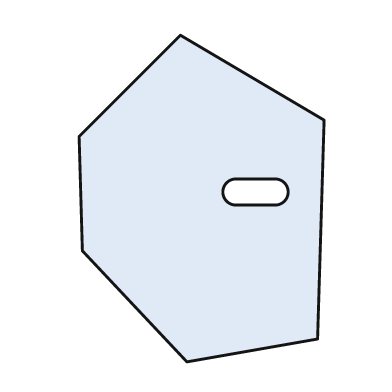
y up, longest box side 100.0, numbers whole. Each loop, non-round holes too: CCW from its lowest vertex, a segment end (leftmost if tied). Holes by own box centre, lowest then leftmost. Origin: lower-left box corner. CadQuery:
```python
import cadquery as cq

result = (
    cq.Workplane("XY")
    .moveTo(33.0, 0.0)
    .lineTo(73.0, 7.0)
    .lineTo(75.0, 74.0)
    .lineTo(31.0, 100.0)
    .lineTo(0.0, 69.0)
    .lineTo(1.0, 34.0)
    .close()
    .moveTo(48.0, 48.0)
    .lineTo(60.0, 48.0)
    .threePointArc((64.0, 52.0), (60.0, 56.0))
    .lineTo(48.0, 56.0)
    .threePointArc((44.0, 52.0), (48.0, 48.0))
    .close()
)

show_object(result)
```